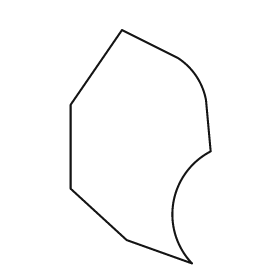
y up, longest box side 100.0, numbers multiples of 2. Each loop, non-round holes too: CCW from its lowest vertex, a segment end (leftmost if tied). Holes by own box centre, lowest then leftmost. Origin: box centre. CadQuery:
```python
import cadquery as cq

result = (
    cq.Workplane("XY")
    .moveTo(22.0, -50.0)
    .threePointArc((14.0, -24.0), (30.0, -2.0))
    .lineTo(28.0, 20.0)
    .threePointArc((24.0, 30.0), (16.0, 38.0))
    .lineTo(-8.0, 50.0)
    .lineTo(-30.0, 18.0)
    .lineTo(-30.0, -18.0)
    .lineTo(-6.0, -40.0)
    .close()
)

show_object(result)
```